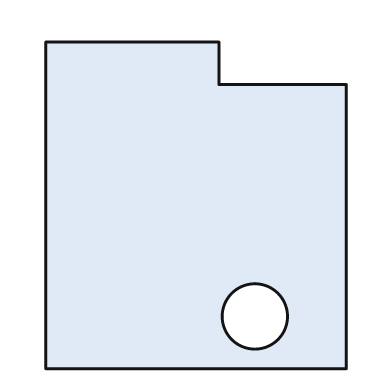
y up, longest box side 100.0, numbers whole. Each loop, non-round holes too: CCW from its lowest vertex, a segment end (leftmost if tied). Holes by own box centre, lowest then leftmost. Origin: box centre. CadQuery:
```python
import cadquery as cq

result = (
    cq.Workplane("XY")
    .moveTo(-46.0, -50.0)
    .lineTo(46.0, -50.0)
    .lineTo(46.0, 37.0)
    .lineTo(7.0, 37.0)
    .lineTo(7.0, 50.0)
    .lineTo(-46.0, 50.0)
    .close()
    .moveTo(18.0, -34.0)
    .circle(10.0)
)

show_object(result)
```